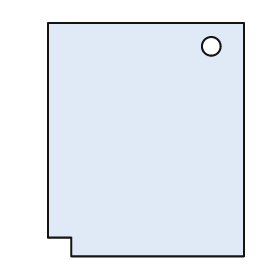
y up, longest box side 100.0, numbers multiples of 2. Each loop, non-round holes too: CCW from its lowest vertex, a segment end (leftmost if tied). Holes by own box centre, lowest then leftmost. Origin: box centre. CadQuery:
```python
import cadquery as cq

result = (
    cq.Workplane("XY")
    .moveTo(-32.0, -50.0)
    .lineTo(42.0, -50.0)
    .lineTo(42.0, 50.0)
    .lineTo(-42.0, 50.0)
    .lineTo(-42.0, -42.0)
    .lineTo(-32.0, -42.0)
    .close()
    .moveTo(28.0, 40.0)
    .circle(4.0)
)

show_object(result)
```